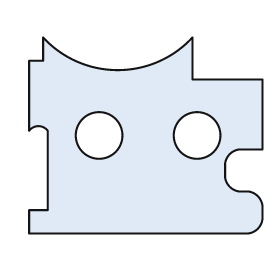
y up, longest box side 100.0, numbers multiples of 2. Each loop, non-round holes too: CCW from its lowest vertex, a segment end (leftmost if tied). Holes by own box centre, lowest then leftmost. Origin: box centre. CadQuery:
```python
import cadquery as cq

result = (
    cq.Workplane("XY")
    .moveTo(-50.0, -42.0)
    .lineTo(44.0, -42.0)
    .threePointArc((48.0, -40.0), (50.0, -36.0))
    .lineTo(50.0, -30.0)
    .threePointArc((48.0, -26.0), (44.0, -24.0))
    .lineTo(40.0, -24.0)
    .threePointArc((36.0, -22.0), (34.0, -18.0))
    .lineTo(34.0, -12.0)
    .threePointArc((36.0, -8.0), (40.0, -6.0))
    .lineTo(50.0, -6.0)
    .lineTo(50.0, 24.0)
    .lineTo(20.0, 24.0)
    .lineTo(20.0, 42.0)
    .threePointArc((-12.0, 28.0), (-44.0, 42.0))
    .lineTo(-44.0, 32.0)
    .lineTo(-50.0, 32.0)
    .lineTo(-50.0, 2.0)
    .threePointArc((-46.0, 4.0), (-42.0, 2.0))
    .lineTo(-42.0, -32.0)
    .lineTo(-50.0, -32.0)
    .close()
    .moveTo(-20.0, 0.0)
    .circle(10.0)
    .moveTo(22.0, 0.0)
    .circle(10.0)
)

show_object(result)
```